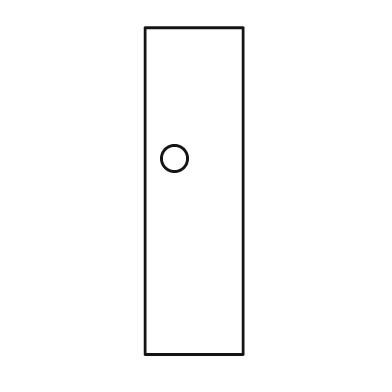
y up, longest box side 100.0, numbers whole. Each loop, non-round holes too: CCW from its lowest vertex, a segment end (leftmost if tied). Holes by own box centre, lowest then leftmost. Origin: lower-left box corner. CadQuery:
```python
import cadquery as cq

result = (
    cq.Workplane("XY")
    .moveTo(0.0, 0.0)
    .lineTo(30.0, 0.0)
    .lineTo(30.0, 100.0)
    .lineTo(0.0, 100.0)
    .close()
    .moveTo(9.0, 60.0)
    .circle(4.0)
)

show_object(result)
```